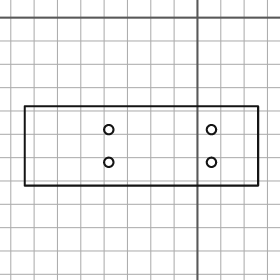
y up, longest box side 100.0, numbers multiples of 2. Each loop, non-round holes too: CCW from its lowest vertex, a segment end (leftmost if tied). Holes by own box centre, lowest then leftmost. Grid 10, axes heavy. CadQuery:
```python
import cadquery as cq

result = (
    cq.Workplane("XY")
    .moveTo(-74.0, -72.0)
    .lineTo(26.0, -72.0)
    .lineTo(26.0, -38.0)
    .lineTo(-74.0, -38.0)
    .close()
    .moveTo(-38.0, -62.0)
    .circle(2.0)
    .moveTo(6.0, -62.0)
    .circle(2.0)
    .moveTo(-38.0, -48.0)
    .circle(2.0)
    .moveTo(6.0, -48.0)
    .circle(2.0)
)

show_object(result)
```